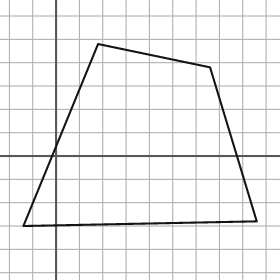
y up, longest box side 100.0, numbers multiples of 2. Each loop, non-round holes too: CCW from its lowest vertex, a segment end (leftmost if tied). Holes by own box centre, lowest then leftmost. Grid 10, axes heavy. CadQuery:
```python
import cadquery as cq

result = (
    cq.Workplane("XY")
    .moveTo(-14.0, -30.0)
    .lineTo(86.0, -28.0)
    .lineTo(66.0, 38.0)
    .lineTo(18.0, 48.0)
    .close()
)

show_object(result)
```